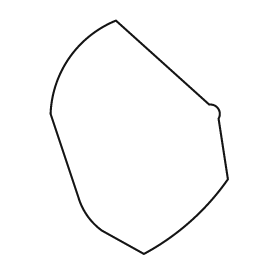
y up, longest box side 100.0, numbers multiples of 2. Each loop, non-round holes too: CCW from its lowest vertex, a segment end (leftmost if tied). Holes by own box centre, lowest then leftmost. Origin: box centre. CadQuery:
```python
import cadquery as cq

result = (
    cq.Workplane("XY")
    .moveTo(2.0, -50.0)
    .threePointArc((22.0, -36.0), (38.0, -18.0))
    .lineTo(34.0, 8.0)
    .threePointArc((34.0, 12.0), (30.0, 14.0))
    .lineTo(-10.0, 50.0)
    .threePointArc((-30.0, 34.0), (-38.0, 10.0))
    .lineTo(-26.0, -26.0)
    .threePointArc((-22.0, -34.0), (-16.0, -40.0))
    .close()
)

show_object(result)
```